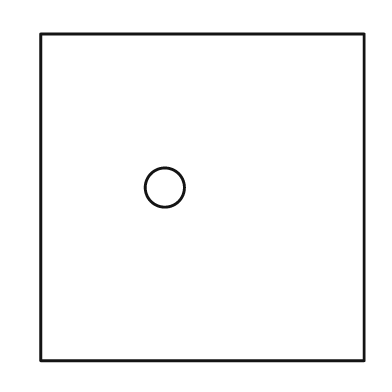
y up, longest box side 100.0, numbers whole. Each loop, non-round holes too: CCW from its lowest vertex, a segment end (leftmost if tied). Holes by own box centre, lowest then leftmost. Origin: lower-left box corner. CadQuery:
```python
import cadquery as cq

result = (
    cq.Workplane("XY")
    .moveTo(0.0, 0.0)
    .lineTo(99.0, 0.0)
    .lineTo(99.0, 100.0)
    .lineTo(0.0, 100.0)
    .close()
    .moveTo(38.0, 53.0)
    .circle(6.0)
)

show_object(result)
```